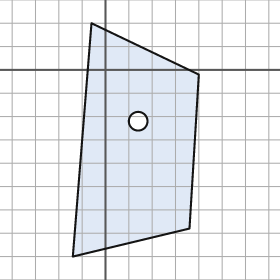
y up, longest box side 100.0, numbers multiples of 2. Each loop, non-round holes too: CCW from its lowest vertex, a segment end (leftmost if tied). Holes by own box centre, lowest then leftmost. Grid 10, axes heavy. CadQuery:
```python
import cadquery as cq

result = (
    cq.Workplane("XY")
    .moveTo(-14.0, -80.0)
    .lineTo(36.0, -68.0)
    .lineTo(40.0, -2.0)
    .lineTo(-6.0, 20.0)
    .close()
    .moveTo(14.0, -22.0)
    .circle(4.0)
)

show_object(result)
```